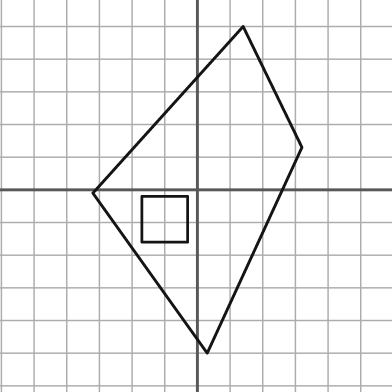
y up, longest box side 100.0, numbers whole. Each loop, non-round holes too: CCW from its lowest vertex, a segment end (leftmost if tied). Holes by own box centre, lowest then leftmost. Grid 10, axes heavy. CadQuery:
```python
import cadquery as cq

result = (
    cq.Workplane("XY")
    .moveTo(3.0, -50.0)
    .lineTo(32.0, 13.0)
    .lineTo(14.0, 50.0)
    .lineTo(-32.0, -1.0)
    .close()
    .moveTo(-17.0, -16.0)
    .lineTo(-3.0, -16.0)
    .lineTo(-3.0, -2.0)
    .lineTo(-17.0, -2.0)
    .close()
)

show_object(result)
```